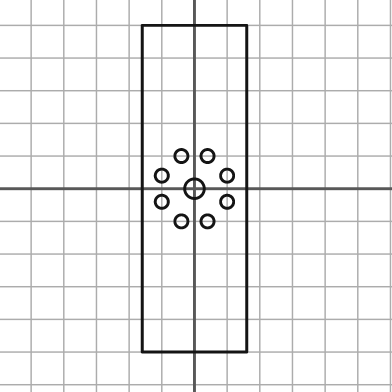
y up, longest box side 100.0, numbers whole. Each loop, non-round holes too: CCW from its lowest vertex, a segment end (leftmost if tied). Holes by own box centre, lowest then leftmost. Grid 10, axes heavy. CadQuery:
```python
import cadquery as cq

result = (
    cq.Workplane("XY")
    .moveTo(-16.0, -50.0)
    .lineTo(16.0, -50.0)
    .lineTo(16.0, 50.0)
    .lineTo(-16.0, 50.0)
    .close()
    .moveTo(-4.0, -10.0)
    .circle(2.0)
    .moveTo(4.0, -10.0)
    .circle(2.0)
    .moveTo(-10.0, -4.0)
    .circle(2.0)
    .moveTo(10.0, -4.0)
    .circle(2.0)
    .moveTo(0.0, 0.0)
    .circle(3.0)
    .moveTo(-10.0, 4.0)
    .circle(2.0)
    .moveTo(10.0, 4.0)
    .circle(2.0)
    .moveTo(-4.0, 10.0)
    .circle(2.0)
    .moveTo(4.0, 10.0)
    .circle(2.0)
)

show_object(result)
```